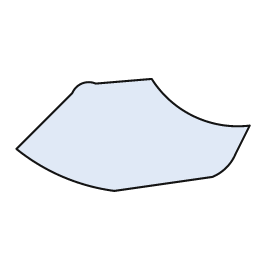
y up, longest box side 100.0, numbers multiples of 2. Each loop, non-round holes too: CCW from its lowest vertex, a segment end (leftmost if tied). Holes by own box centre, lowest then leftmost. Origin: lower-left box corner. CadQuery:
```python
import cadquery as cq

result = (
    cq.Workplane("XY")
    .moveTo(42.0, 0.0)
    .lineTo(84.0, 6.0)
    .threePointArc((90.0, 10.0), (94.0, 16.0))
    .lineTo(100.0, 28.0)
    .threePointArc((76.0, 32.0), (58.0, 48.0))
    .lineTo(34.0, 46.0)
    .threePointArc((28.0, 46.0), (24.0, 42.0))
    .lineTo(0.0, 18.0)
    .threePointArc((20.0, 6.0), (42.0, 0.0))
    .close()
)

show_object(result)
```